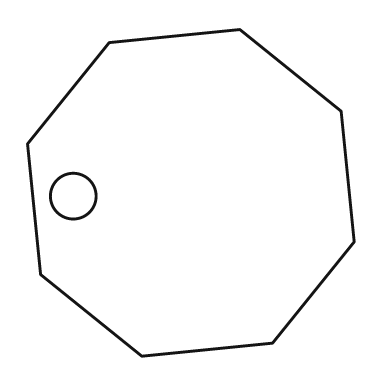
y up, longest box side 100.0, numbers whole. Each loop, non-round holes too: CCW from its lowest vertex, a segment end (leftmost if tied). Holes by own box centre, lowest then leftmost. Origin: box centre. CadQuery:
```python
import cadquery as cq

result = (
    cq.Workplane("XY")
    .moveTo(-15.0, -50.0)
    .lineTo(25.0, -46.0)
    .lineTo(50.0, -15.0)
    .lineTo(46.0, 25.0)
    .lineTo(15.0, 50.0)
    .lineTo(-25.0, 46.0)
    .lineTo(-50.0, 15.0)
    .lineTo(-46.0, -25.0)
    .close()
    .moveTo(-36.0, -1.0)
    .circle(7.0)
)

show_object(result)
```